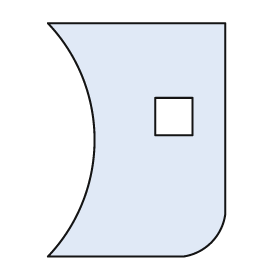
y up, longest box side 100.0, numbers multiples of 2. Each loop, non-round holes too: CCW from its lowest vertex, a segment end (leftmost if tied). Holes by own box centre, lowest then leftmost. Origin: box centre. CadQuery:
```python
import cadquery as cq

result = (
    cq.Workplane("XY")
    .moveTo(-38.0, -50.0)
    .lineTo(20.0, -50.0)
    .threePointArc((32.0, -44.0), (38.0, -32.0))
    .lineTo(38.0, 50.0)
    .lineTo(-38.0, 50.0)
    .threePointArc((-18.0, 0.0), (-38.0, -50.0))
    .close()
    .moveTo(8.0, 2.0)
    .lineTo(24.0, 2.0)
    .lineTo(24.0, 18.0)
    .lineTo(8.0, 18.0)
    .close()
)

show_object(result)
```